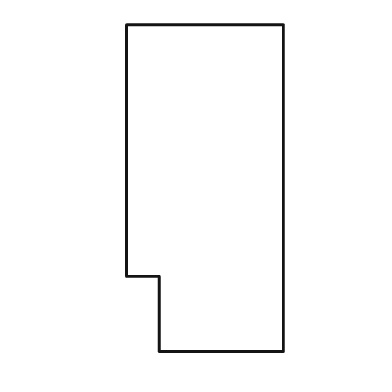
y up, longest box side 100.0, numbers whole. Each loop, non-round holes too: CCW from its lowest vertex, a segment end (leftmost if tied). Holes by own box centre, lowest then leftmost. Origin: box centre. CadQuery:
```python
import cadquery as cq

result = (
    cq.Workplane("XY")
    .moveTo(-14.0, -50.0)
    .lineTo(24.0, -50.0)
    .lineTo(24.0, 50.0)
    .lineTo(-24.0, 50.0)
    .lineTo(-24.0, -27.0)
    .lineTo(-14.0, -27.0)
    .close()
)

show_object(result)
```